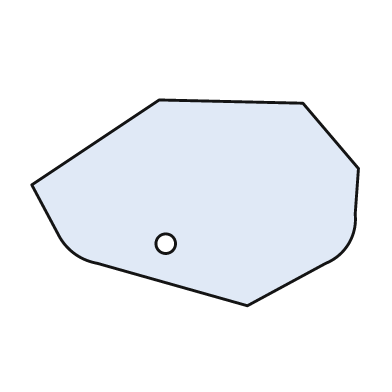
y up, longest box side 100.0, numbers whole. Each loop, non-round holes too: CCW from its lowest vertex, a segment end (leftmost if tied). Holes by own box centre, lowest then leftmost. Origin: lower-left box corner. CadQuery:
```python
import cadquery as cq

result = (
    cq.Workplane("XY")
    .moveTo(66.0, 0.0)
    .lineTo(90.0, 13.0)
    .threePointArc((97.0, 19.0), (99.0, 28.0))
    .lineTo(100.0, 42.0)
    .lineTo(83.0, 62.0)
    .lineTo(39.0, 63.0)
    .lineTo(0.0, 37.0)
    .lineTo(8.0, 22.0)
    .threePointArc((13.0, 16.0), (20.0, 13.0))
    .close()
    .moveTo(41.0, 19.0)
    .circle(3.0)
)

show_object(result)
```